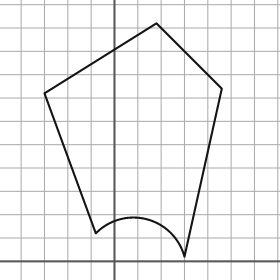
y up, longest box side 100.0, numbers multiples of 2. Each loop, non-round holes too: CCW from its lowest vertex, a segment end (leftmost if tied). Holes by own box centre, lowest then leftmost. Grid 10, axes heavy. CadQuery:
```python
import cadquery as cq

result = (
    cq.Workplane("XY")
    .moveTo(30.0, 2.0)
    .lineTo(46.0, 74.0)
    .lineTo(18.0, 102.0)
    .lineTo(-30.0, 72.0)
    .lineTo(-8.0, 12.0)
    .threePointArc((14.0, 18.0), (30.0, 2.0))
    .close()
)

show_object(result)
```